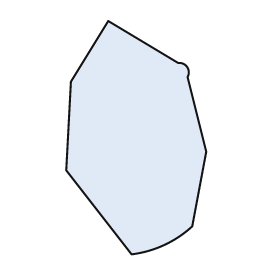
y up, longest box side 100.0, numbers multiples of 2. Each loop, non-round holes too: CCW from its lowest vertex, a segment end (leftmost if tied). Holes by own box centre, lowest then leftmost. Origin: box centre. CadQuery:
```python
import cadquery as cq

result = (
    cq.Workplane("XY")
    .moveTo(-2.0, -50.0)
    .threePointArc((12.0, -46.0), (24.0, -38.0))
    .lineTo(30.0, -6.0)
    .lineTo(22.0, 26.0)
    .threePointArc((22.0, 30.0), (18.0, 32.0))
    .lineTo(-12.0, 50.0)
    .lineTo(-28.0, 24.0)
    .lineTo(-30.0, -14.0)
    .close()
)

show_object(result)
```